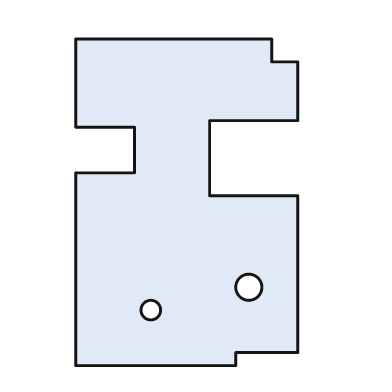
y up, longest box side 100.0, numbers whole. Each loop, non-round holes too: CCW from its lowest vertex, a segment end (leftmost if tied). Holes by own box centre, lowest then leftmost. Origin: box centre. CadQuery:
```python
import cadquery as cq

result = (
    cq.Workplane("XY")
    .moveTo(-34.0, -50.0)
    .lineTo(15.0, -50.0)
    .lineTo(15.0, -46.0)
    .lineTo(34.0, -46.0)
    .lineTo(34.0, 2.0)
    .lineTo(7.0, 2.0)
    .lineTo(7.0, 25.0)
    .lineTo(34.0, 25.0)
    .lineTo(34.0, 43.0)
    .lineTo(26.0, 43.0)
    .lineTo(26.0, 50.0)
    .lineTo(-34.0, 50.0)
    .lineTo(-34.0, 23.0)
    .lineTo(-16.0, 23.0)
    .lineTo(-16.0, 9.0)
    .lineTo(-34.0, 9.0)
    .close()
    .moveTo(-11.0, -33.0)
    .circle(3.0)
    .moveTo(19.0, -26.0)
    .circle(4.0)
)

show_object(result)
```